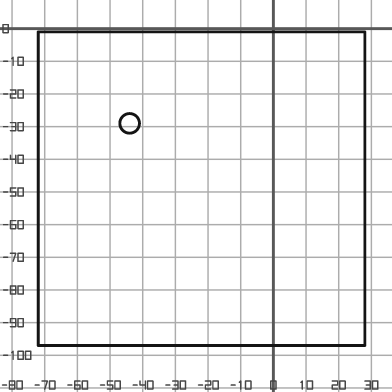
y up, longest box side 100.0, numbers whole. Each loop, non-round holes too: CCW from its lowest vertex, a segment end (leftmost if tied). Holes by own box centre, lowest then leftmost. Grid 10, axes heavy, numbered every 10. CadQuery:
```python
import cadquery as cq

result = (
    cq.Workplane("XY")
    .moveTo(-72.0, -97.0)
    .lineTo(28.0, -97.0)
    .lineTo(28.0, -1.0)
    .lineTo(-72.0, -1.0)
    .close()
    .moveTo(-44.0, -29.0)
    .circle(3.0)
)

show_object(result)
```